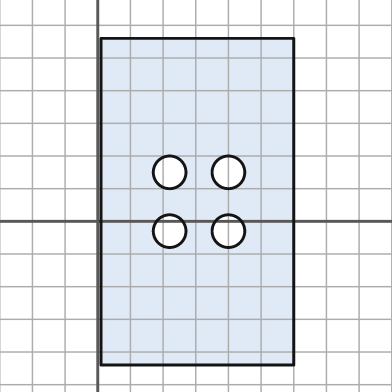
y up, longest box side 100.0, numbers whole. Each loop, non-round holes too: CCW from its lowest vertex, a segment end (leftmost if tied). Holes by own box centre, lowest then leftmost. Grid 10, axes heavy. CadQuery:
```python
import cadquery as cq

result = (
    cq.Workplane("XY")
    .moveTo(1.0, -44.0)
    .lineTo(60.0, -44.0)
    .lineTo(60.0, 56.0)
    .lineTo(1.0, 56.0)
    .close()
    .moveTo(22.0, -3.0)
    .circle(5.0)
    .moveTo(40.0, -3.0)
    .circle(5.0)
    .moveTo(22.0, 15.0)
    .circle(5.0)
    .moveTo(40.0, 15.0)
    .circle(5.0)
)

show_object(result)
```